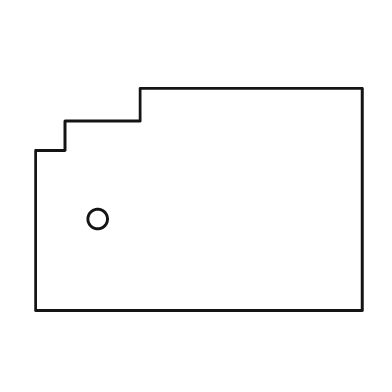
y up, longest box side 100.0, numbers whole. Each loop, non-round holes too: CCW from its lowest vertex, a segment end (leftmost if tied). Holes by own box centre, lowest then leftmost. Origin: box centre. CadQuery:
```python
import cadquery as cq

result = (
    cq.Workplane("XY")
    .moveTo(-50.0, -34.0)
    .lineTo(50.0, -34.0)
    .lineTo(50.0, 34.0)
    .lineTo(-18.0, 34.0)
    .lineTo(-18.0, 24.0)
    .lineTo(-41.0, 24.0)
    .lineTo(-41.0, 15.0)
    .lineTo(-50.0, 15.0)
    .close()
    .moveTo(-31.0, -6.0)
    .circle(3.0)
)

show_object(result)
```